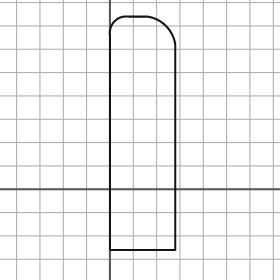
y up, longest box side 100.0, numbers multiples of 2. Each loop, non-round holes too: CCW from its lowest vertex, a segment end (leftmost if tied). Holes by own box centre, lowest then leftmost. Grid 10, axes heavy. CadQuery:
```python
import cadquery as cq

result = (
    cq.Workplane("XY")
    .moveTo(0.0, -26.0)
    .lineTo(28.0, -26.0)
    .lineTo(28.0, 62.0)
    .threePointArc((24.0, 70.0), (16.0, 74.0))
    .lineTo(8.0, 74.0)
    .threePointArc((2.0, 72.0), (0.0, 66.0))
    .close()
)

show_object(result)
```